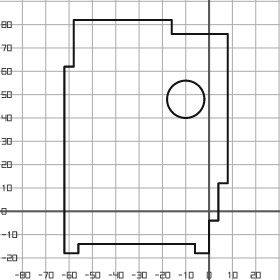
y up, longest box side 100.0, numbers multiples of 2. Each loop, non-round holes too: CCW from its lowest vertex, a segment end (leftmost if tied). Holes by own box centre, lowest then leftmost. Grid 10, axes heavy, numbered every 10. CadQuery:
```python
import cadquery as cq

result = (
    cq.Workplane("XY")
    .moveTo(-62.0, -18.0)
    .lineTo(-56.0, -18.0)
    .lineTo(-56.0, -14.0)
    .lineTo(-6.0, -14.0)
    .lineTo(-6.0, -18.0)
    .lineTo(0.0, -18.0)
    .lineTo(0.0, -4.0)
    .lineTo(4.0, -4.0)
    .lineTo(4.0, 12.0)
    .lineTo(8.0, 12.0)
    .lineTo(8.0, 76.0)
    .lineTo(-16.0, 76.0)
    .lineTo(-16.0, 82.0)
    .lineTo(-58.0, 82.0)
    .lineTo(-58.0, 62.0)
    .lineTo(-62.0, 62.0)
    .close()
    .moveTo(-10.0, 48.0)
    .circle(8.0)
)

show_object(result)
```